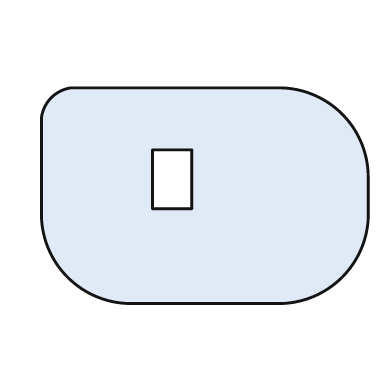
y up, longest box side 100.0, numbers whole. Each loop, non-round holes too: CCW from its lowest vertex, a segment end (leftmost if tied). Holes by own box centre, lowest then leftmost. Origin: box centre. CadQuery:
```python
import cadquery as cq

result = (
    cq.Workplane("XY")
    .moveTo(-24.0, -33.0)
    .lineTo(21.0, -33.0)
    .threePointArc((42.0, -25.0), (50.0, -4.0))
    .lineTo(50.0, 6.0)
    .threePointArc((42.0, 25.0), (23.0, 33.0))
    .lineTo(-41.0, 33.0)
    .threePointArc((-47.0, 30.0), (-50.0, 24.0))
    .lineTo(-50.0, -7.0)
    .threePointArc((-42.0, -25.0), (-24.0, -33.0))
    .close()
    .moveTo(-16.0, -4.0)
    .lineTo(-4.0, -4.0)
    .lineTo(-4.0, 14.0)
    .lineTo(-16.0, 14.0)
    .close()
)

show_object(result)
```